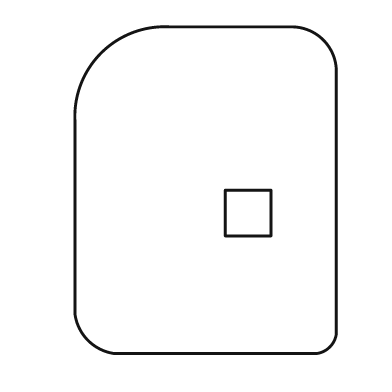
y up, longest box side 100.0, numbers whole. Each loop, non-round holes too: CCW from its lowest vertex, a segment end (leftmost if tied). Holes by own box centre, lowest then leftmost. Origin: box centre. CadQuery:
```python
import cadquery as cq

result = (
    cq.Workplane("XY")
    .moveTo(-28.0, -50.0)
    .lineTo(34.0, -50.0)
    .threePointArc((38.0, -48.0), (40.0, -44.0))
    .lineTo(40.0, 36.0)
    .threePointArc((36.0, 46.0), (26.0, 50.0))
    .lineTo(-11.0, 50.0)
    .threePointArc((-32.0, 42.0), (-40.0, 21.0))
    .lineTo(-40.0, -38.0)
    .threePointArc((-36.0, -46.0), (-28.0, -50.0))
    .close()
    .moveTo(6.0, -14.0)
    .lineTo(20.0, -14.0)
    .lineTo(20.0, 0.0)
    .lineTo(6.0, 0.0)
    .close()
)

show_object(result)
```